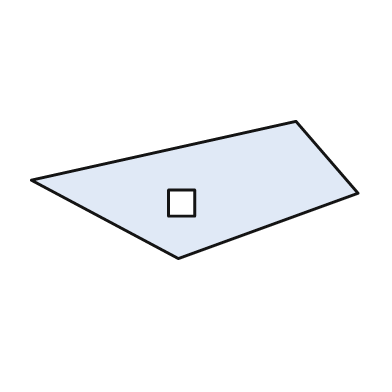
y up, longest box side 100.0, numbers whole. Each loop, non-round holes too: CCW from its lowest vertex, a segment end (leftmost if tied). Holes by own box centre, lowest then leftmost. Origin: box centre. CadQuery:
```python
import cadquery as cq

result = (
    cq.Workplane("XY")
    .moveTo(-5.0, -21.0)
    .lineTo(50.0, -1.0)
    .lineTo(31.0, 21.0)
    .lineTo(-50.0, 3.0)
    .close()
    .moveTo(-8.0, -8.0)
    .lineTo(0.0, -8.0)
    .lineTo(0.0, 0.0)
    .lineTo(-8.0, 0.0)
    .close()
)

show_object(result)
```